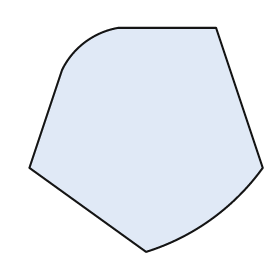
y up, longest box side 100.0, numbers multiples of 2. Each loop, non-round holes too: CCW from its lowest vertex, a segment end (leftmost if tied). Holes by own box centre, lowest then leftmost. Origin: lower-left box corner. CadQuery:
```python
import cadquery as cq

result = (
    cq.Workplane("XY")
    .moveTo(50.0, 0.0)
    .threePointArc((78.0, 14.0), (100.0, 36.0))
    .lineTo(80.0, 96.0)
    .lineTo(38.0, 96.0)
    .threePointArc((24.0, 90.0), (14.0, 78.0))
    .lineTo(0.0, 36.0)
    .close()
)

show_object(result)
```